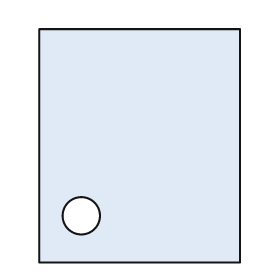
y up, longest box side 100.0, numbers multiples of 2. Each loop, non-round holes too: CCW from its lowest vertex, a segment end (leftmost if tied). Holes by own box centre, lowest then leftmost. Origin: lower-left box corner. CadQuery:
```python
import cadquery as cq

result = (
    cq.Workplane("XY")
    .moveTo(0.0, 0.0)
    .lineTo(86.0, 0.0)
    .lineTo(86.0, 100.0)
    .lineTo(0.0, 100.0)
    .close()
    .moveTo(18.0, 20.0)
    .circle(8.0)
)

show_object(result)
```